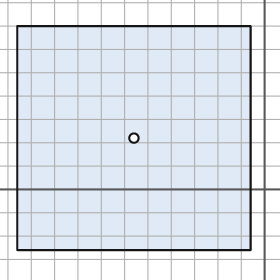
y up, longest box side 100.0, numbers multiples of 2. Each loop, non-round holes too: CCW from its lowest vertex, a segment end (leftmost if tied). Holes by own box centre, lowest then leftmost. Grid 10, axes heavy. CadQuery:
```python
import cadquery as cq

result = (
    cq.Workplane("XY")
    .moveTo(-106.0, -26.0)
    .lineTo(-6.0, -26.0)
    .lineTo(-6.0, 70.0)
    .lineTo(-106.0, 70.0)
    .close()
    .moveTo(-56.0, 22.0)
    .circle(2.0)
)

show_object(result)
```